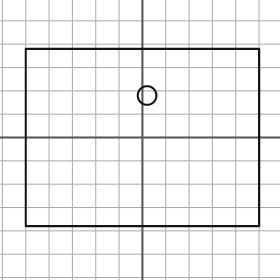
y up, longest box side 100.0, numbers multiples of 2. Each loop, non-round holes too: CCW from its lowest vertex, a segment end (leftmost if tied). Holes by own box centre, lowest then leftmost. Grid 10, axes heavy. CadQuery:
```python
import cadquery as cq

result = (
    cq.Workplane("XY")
    .moveTo(-50.0, -38.0)
    .lineTo(50.0, -38.0)
    .lineTo(50.0, 38.0)
    .lineTo(-50.0, 38.0)
    .close()
    .moveTo(2.0, 18.0)
    .circle(4.0)
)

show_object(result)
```